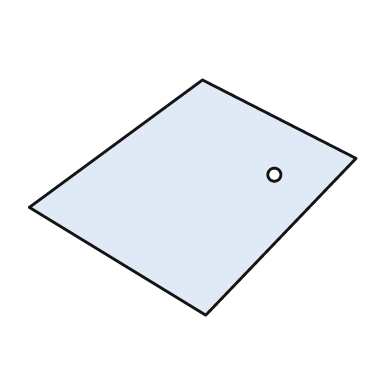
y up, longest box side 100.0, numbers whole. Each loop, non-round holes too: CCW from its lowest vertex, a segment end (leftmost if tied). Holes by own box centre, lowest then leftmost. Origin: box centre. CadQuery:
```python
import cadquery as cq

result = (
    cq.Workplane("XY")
    .moveTo(4.0, -36.0)
    .lineTo(50.0, 12.0)
    .lineTo(3.0, 36.0)
    .lineTo(-50.0, -3.0)
    .close()
    .moveTo(25.0, 7.0)
    .circle(2.0)
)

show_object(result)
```